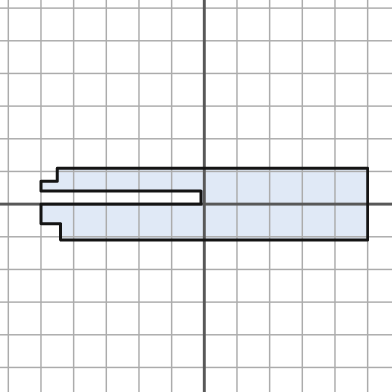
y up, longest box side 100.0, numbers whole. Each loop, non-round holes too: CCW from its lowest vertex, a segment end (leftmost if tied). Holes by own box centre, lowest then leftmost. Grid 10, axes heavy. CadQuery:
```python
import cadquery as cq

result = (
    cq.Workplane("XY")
    .moveTo(-44.0, -11.0)
    .lineTo(50.0, -11.0)
    .lineTo(50.0, 11.0)
    .lineTo(-45.0, 11.0)
    .lineTo(-45.0, 7.0)
    .lineTo(-50.0, 7.0)
    .lineTo(-50.0, 4.0)
    .lineTo(-1.0, 4.0)
    .lineTo(-1.0, 0.0)
    .lineTo(-50.0, 0.0)
    .lineTo(-50.0, -6.0)
    .lineTo(-44.0, -6.0)
    .close()
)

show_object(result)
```